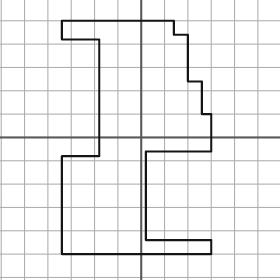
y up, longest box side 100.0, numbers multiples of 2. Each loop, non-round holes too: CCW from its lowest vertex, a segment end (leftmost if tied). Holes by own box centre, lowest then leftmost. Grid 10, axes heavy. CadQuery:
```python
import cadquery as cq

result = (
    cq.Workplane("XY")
    .moveTo(-34.0, -50.0)
    .lineTo(30.0, -50.0)
    .lineTo(30.0, -44.0)
    .lineTo(2.0, -44.0)
    .lineTo(2.0, -6.0)
    .lineTo(30.0, -6.0)
    .lineTo(30.0, 10.0)
    .lineTo(26.0, 10.0)
    .lineTo(26.0, 24.0)
    .lineTo(20.0, 24.0)
    .lineTo(20.0, 44.0)
    .lineTo(14.0, 44.0)
    .lineTo(14.0, 50.0)
    .lineTo(-34.0, 50.0)
    .lineTo(-34.0, 42.0)
    .lineTo(-18.0, 42.0)
    .lineTo(-18.0, -8.0)
    .lineTo(-34.0, -8.0)
    .close()
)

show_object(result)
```